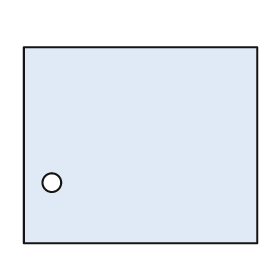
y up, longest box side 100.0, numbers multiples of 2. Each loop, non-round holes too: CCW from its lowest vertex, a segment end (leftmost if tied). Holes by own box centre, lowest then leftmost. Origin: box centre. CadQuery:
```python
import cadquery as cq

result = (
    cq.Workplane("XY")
    .moveTo(-50.0, -42.0)
    .lineTo(50.0, -42.0)
    .lineTo(50.0, 42.0)
    .lineTo(-50.0, 42.0)
    .close()
    .moveTo(-38.0, -16.0)
    .circle(4.0)
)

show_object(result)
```